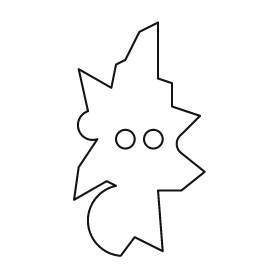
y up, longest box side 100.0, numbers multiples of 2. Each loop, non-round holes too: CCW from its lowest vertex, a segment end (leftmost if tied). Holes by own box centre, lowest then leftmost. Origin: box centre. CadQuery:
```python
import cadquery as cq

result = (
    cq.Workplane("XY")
    .moveTo(-8.0, -50.0)
    .lineTo(-2.0, -42.0)
    .lineTo(10.0, -48.0)
    .lineTo(8.0, -22.0)
    .lineTo(18.0, -22.0)
    .lineTo(28.0, -14.0)
    .lineTo(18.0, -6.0)
    .threePointArc((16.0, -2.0), (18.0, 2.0))
    .lineTo(26.0, 10.0)
    .lineTo(14.0, 14.0)
    .lineTo(14.0, 24.0)
    .lineTo(8.0, 26.0)
    .lineTo(8.0, 50.0)
    .lineTo(0.0, 46.0)
    .lineTo(-6.0, 34.0)
    .lineTo(-10.0, 32.0)
    .lineTo(-12.0, 22.0)
    .lineTo(-26.0, 30.0)
    .lineTo(-22.0, 12.0)
    .threePointArc((-26.0, 4.0), (-18.0, 0.0))
    .lineTo(-26.0, -12.0)
    .lineTo(-28.0, -26.0)
    .lineTo(-14.0, -18.0)
    .lineTo(-10.0, -20.0)
    .threePointArc((-22.0, -36.0), (-8.0, -50.0))
    .close()
    .moveTo(-6.0, 0.0)
    .circle(4.0)
    .moveTo(6.0, 0.0)
    .circle(4.0)
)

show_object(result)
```